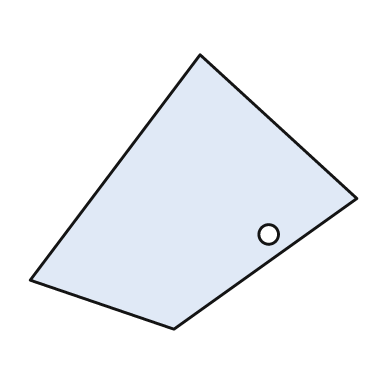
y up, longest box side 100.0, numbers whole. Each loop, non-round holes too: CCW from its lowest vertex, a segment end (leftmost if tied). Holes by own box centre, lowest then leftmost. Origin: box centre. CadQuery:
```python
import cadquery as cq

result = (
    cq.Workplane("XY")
    .moveTo(-6.0, -42.0)
    .lineTo(50.0, -2.0)
    .lineTo(2.0, 42.0)
    .lineTo(-50.0, -27.0)
    .close()
    .moveTo(23.0, -13.0)
    .circle(3.0)
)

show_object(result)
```